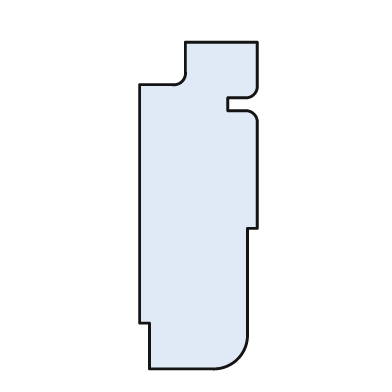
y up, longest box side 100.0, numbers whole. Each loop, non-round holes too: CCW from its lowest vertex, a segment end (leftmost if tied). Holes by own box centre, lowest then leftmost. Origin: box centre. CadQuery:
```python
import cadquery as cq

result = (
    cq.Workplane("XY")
    .moveTo(-15.0, -50.0)
    .lineTo(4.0, -50.0)
    .threePointArc((12.0, -47.0), (15.0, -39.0))
    .lineTo(15.0, -7.0)
    .lineTo(18.0, -7.0)
    .lineTo(18.0, 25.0)
    .threePointArc((17.0, 28.0), (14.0, 29.0))
    .lineTo(9.0, 29.0)
    .lineTo(9.0, 33.0)
    .lineTo(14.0, 33.0)
    .threePointArc((17.0, 34.0), (18.0, 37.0))
    .lineTo(18.0, 50.0)
    .lineTo(-4.0, 50.0)
    .lineTo(-4.0, 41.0)
    .threePointArc((-5.0, 38.0), (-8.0, 37.0))
    .lineTo(-18.0, 37.0)
    .lineTo(-18.0, -36.0)
    .lineTo(-15.0, -36.0)
    .close()
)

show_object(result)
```